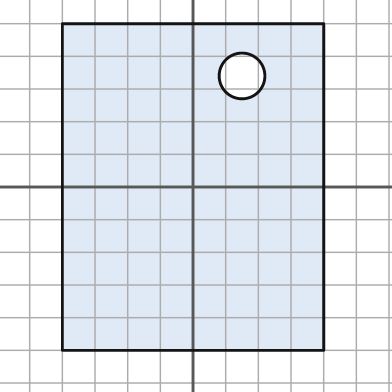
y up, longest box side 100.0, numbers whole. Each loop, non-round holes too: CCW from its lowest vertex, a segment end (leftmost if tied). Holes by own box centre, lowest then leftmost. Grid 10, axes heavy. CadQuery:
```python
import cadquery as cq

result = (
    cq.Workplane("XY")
    .moveTo(-40.0, -50.0)
    .lineTo(40.0, -50.0)
    .lineTo(40.0, 50.0)
    .lineTo(-40.0, 50.0)
    .close()
    .moveTo(15.0, 34.0)
    .circle(7.0)
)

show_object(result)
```